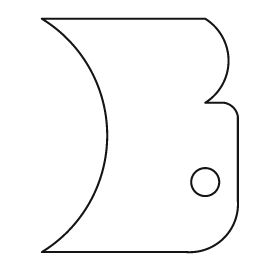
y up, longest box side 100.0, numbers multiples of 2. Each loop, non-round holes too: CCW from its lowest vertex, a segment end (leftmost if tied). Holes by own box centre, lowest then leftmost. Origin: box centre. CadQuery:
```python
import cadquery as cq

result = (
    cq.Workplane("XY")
    .moveTo(-42.0, -50.0)
    .lineTo(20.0, -50.0)
    .threePointArc((36.0, -44.0), (42.0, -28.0))
    .lineTo(42.0, 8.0)
    .threePointArc((40.0, 12.0), (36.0, 14.0))
    .lineTo(28.0, 14.0)
    .threePointArc((38.0, 32.0), (28.0, 50.0))
    .lineTo(-42.0, 50.0)
    .threePointArc((-14.0, 0.0), (-42.0, -50.0))
    .close()
    .moveTo(28.0, -20.0)
    .circle(6.0)
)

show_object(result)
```